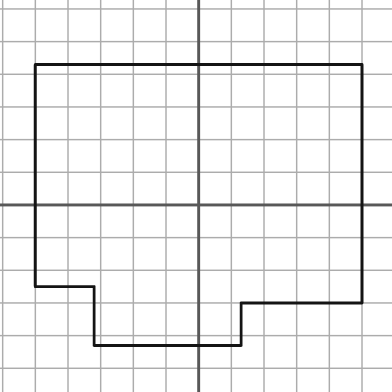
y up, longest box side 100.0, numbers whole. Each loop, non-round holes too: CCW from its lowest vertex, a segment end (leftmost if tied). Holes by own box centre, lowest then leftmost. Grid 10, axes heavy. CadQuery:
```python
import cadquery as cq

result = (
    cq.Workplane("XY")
    .moveTo(-32.0, -43.0)
    .lineTo(13.0, -43.0)
    .lineTo(13.0, -30.0)
    .lineTo(50.0, -30.0)
    .lineTo(50.0, 43.0)
    .lineTo(-50.0, 43.0)
    .lineTo(-50.0, -25.0)
    .lineTo(-32.0, -25.0)
    .close()
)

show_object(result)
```